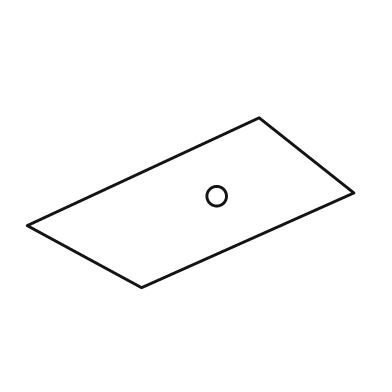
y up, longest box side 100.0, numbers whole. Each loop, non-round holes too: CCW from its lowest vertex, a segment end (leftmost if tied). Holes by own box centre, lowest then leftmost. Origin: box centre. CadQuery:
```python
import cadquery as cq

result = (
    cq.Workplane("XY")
    .moveTo(-15.0, -26.0)
    .lineTo(50.0, 3.0)
    .lineTo(21.0, 26.0)
    .lineTo(-50.0, -7.0)
    .close()
    .moveTo(8.0, 2.0)
    .circle(3.0)
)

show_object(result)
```